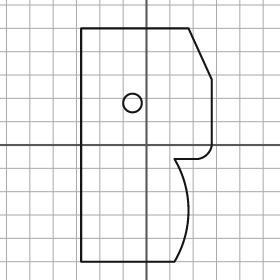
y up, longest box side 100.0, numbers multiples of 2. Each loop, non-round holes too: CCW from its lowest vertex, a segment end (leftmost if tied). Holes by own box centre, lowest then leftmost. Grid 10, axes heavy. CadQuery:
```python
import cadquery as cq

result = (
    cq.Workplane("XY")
    .moveTo(-28.0, -50.0)
    .lineTo(12.0, -50.0)
    .threePointArc((18.0, -28.0), (12.0, -6.0))
    .lineTo(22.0, -6.0)
    .threePointArc((26.0, -4.0), (28.0, 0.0))
    .lineTo(28.0, 28.0)
    .lineTo(18.0, 50.0)
    .lineTo(-28.0, 50.0)
    .close()
    .moveTo(-6.0, 18.0)
    .circle(4.0)
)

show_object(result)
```